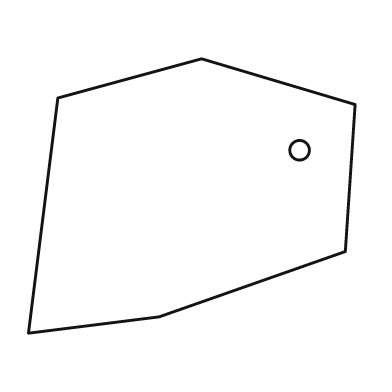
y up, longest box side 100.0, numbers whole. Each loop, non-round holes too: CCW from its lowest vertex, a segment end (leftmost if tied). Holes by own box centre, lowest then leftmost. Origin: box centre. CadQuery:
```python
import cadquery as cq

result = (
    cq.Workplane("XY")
    .moveTo(-50.0, -42.0)
    .lineTo(-10.0, -37.0)
    .lineTo(47.0, -17.0)
    .lineTo(50.0, 28.0)
    .lineTo(3.0, 42.0)
    .lineTo(-41.0, 30.0)
    .close()
    .moveTo(33.0, 14.0)
    .circle(3.0)
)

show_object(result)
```